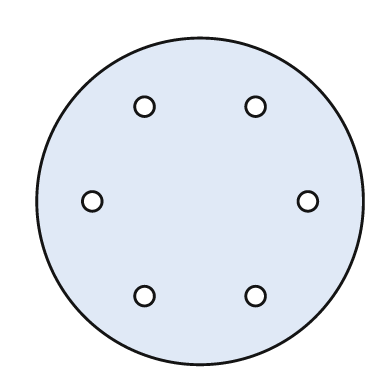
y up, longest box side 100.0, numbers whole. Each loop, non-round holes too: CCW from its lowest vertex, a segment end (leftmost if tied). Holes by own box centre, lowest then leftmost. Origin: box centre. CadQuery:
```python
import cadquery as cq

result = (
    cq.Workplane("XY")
    .moveTo(0.0, 0.0)
    .circle(50.0)
    .moveTo(-17.0, -29.0)
    .circle(3.0)
    .moveTo(17.0, -29.0)
    .circle(3.0)
    .moveTo(-33.0, 0.0)
    .circle(3.0)
    .moveTo(33.0, 0.0)
    .circle(3.0)
    .moveTo(-17.0, 29.0)
    .circle(3.0)
    .moveTo(17.0, 29.0)
    .circle(3.0)
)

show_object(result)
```